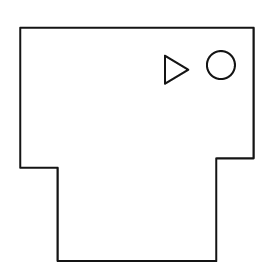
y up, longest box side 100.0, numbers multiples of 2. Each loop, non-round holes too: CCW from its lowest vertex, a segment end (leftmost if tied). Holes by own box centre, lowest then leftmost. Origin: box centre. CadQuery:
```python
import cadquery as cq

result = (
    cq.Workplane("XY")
    .moveTo(-34.0, -50.0)
    .lineTo(34.0, -50.0)
    .lineTo(34.0, -6.0)
    .lineTo(50.0, -6.0)
    .lineTo(50.0, 50.0)
    .lineTo(-50.0, 50.0)
    .lineTo(-50.0, -10.0)
    .lineTo(-34.0, -10.0)
    .close()
    .moveTo(12.0, 26.0)
    .lineTo(22.0, 32.0)
    .lineTo(12.0, 38.0)
    .close()
    .moveTo(36.0, 34.0)
    .circle(6.0)
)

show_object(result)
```